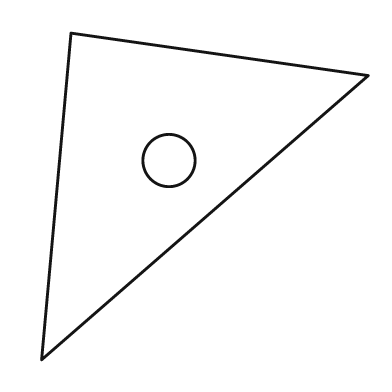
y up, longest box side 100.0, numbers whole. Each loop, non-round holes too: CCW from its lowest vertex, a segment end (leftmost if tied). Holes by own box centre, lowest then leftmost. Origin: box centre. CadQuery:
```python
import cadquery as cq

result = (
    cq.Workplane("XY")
    .moveTo(-50.0, -50.0)
    .lineTo(50.0, 37.0)
    .lineTo(-41.0, 50.0)
    .close()
    .moveTo(-11.0, 11.0)
    .circle(8.0)
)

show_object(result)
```